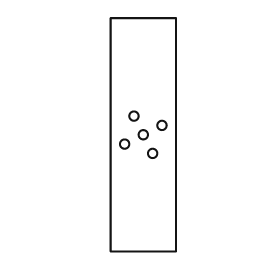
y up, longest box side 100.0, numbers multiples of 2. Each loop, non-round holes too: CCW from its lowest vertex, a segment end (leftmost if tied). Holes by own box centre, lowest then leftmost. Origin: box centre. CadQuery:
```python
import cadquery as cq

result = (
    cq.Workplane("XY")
    .moveTo(-14.0, -50.0)
    .lineTo(14.0, -50.0)
    .lineTo(14.0, 50.0)
    .lineTo(-14.0, 50.0)
    .close()
    .moveTo(4.0, -8.0)
    .circle(2.0)
    .moveTo(-8.0, -4.0)
    .circle(2.0)
    .moveTo(0.0, 0.0)
    .circle(2.0)
    .moveTo(8.0, 4.0)
    .circle(2.0)
    .moveTo(-4.0, 8.0)
    .circle(2.0)
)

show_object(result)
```